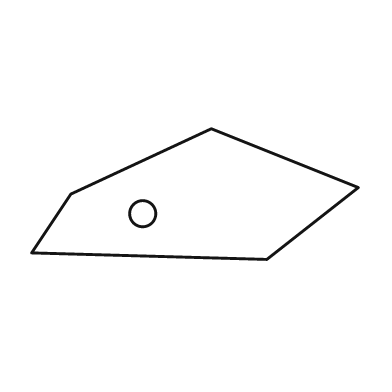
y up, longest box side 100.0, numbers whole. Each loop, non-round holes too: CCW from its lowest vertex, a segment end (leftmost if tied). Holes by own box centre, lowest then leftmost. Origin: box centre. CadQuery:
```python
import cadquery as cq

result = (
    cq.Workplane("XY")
    .moveTo(22.0, -20.0)
    .lineTo(50.0, 2.0)
    .lineTo(5.0, 20.0)
    .lineTo(-38.0, 0.0)
    .lineTo(-50.0, -18.0)
    .close()
    .moveTo(-16.0, -6.0)
    .circle(4.0)
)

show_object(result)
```